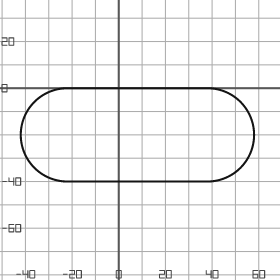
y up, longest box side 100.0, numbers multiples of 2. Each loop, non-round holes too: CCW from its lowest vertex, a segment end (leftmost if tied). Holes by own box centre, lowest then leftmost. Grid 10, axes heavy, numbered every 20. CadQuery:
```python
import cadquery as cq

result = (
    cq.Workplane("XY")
    .moveTo(-22.0, -40.0)
    .lineTo(38.0, -40.0)
    .threePointArc((58.0, -20.0), (38.0, 0.0))
    .lineTo(-22.0, 0.0)
    .threePointArc((-42.0, -20.0), (-22.0, -40.0))
    .close()
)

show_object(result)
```